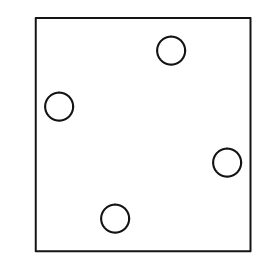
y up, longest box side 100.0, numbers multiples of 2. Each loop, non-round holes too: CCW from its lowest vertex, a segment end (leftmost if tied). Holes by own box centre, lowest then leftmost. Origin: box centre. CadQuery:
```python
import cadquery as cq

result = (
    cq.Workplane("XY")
    .moveTo(-46.0, -50.0)
    .lineTo(46.0, -50.0)
    .lineTo(46.0, 50.0)
    .lineTo(-46.0, 50.0)
    .close()
    .moveTo(-12.0, -36.0)
    .circle(6.0)
    .moveTo(36.0, -12.0)
    .circle(6.0)
    .moveTo(-36.0, 12.0)
    .circle(6.0)
    .moveTo(12.0, 36.0)
    .circle(6.0)
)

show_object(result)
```